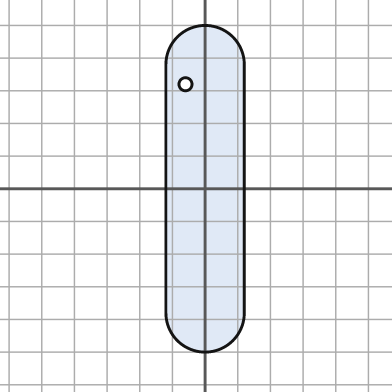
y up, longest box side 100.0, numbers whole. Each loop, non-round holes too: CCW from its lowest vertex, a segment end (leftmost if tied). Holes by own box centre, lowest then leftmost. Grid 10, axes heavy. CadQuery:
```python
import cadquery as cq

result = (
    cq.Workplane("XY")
    .moveTo(-12.0, -38.0)
    .threePointArc((0.0, -50.0), (12.0, -38.0))
    .lineTo(12.0, 38.0)
    .threePointArc((0.0, 50.0), (-12.0, 38.0))
    .close()
    .moveTo(-6.0, 32.0)
    .circle(2.0)
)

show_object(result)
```